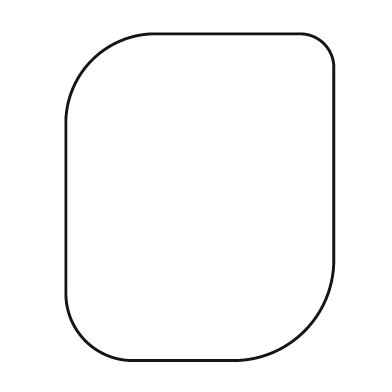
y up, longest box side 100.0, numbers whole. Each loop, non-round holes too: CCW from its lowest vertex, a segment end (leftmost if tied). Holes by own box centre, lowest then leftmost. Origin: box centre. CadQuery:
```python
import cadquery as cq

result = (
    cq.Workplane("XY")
    .moveTo(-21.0, -50.0)
    .lineTo(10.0, -50.0)
    .threePointArc((32.0, -41.0), (41.0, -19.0))
    .lineTo(41.0, 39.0)
    .threePointArc((38.0, 47.0), (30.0, 50.0))
    .lineTo(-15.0, 50.0)
    .threePointArc((-33.0, 42.0), (-41.0, 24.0))
    .lineTo(-41.0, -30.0)
    .threePointArc((-35.0, -44.0), (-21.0, -50.0))
    .close()
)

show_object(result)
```